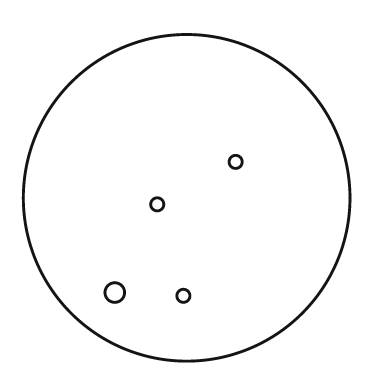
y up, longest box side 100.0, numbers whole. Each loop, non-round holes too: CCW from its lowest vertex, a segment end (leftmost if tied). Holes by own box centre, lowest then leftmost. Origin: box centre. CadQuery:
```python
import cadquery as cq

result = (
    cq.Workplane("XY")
    .moveTo(0.0, 0.0)
    .circle(50.0)
    .moveTo(-1.0, -30.0)
    .circle(2.0)
    .moveTo(-22.0, -29.0)
    .circle(3.0)
    .moveTo(-9.0, -2.0)
    .circle(2.0)
    .moveTo(15.0, 11.0)
    .circle(2.0)
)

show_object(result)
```